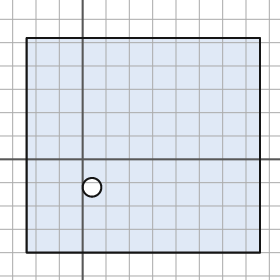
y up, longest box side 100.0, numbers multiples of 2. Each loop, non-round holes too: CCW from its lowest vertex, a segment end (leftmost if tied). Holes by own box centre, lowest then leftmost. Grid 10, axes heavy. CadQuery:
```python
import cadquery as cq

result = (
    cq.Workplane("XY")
    .moveTo(-24.0, -40.0)
    .lineTo(76.0, -40.0)
    .lineTo(76.0, 52.0)
    .lineTo(-24.0, 52.0)
    .close()
    .moveTo(4.0, -12.0)
    .circle(4.0)
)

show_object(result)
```